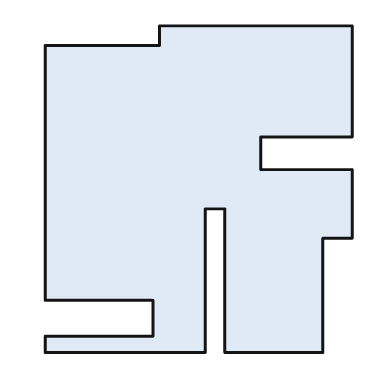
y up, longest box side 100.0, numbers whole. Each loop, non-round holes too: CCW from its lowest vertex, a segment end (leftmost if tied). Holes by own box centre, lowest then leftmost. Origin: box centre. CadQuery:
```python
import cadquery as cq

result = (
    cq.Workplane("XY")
    .moveTo(-47.0, -50.0)
    .lineTo(2.0, -50.0)
    .lineTo(2.0, -6.0)
    .lineTo(8.0, -6.0)
    .lineTo(8.0, -50.0)
    .lineTo(38.0, -50.0)
    .lineTo(38.0, -15.0)
    .lineTo(47.0, -15.0)
    .lineTo(47.0, 6.0)
    .lineTo(19.0, 6.0)
    .lineTo(19.0, 16.0)
    .lineTo(47.0, 16.0)
    .lineTo(47.0, 50.0)
    .lineTo(-12.0, 50.0)
    .lineTo(-12.0, 44.0)
    .lineTo(-47.0, 44.0)
    .lineTo(-47.0, -34.0)
    .lineTo(-14.0, -34.0)
    .lineTo(-14.0, -45.0)
    .lineTo(-47.0, -45.0)
    .close()
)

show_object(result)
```